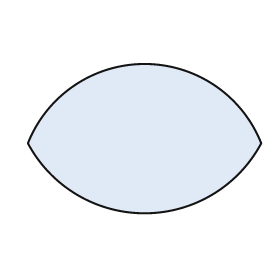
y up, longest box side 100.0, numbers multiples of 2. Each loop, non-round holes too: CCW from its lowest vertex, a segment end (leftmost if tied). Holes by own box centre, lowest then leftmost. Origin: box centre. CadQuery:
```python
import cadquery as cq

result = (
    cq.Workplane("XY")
    .moveTo(-50.0, -2.0)
    .threePointArc((0.0, -32.0), (50.0, -2.0))
    .threePointArc((0.0, 32.0), (-50.0, -2.0))
    .close()
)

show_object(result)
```